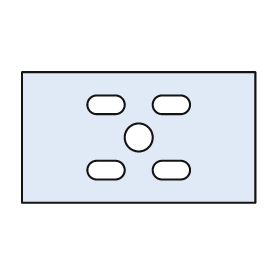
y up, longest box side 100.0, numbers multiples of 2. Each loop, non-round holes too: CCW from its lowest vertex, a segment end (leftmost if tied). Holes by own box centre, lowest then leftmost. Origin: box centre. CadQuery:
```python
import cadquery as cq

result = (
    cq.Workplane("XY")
    .moveTo(-50.0, -28.0)
    .lineTo(50.0, -28.0)
    .lineTo(50.0, 28.0)
    .lineTo(-50.0, 28.0)
    .close()
    .moveTo(-18.0, -18.0)
    .lineTo(-10.0, -18.0)
    .threePointArc((-6.0, -14.0), (-10.0, -10.0))
    .lineTo(-18.0, -10.0)
    .threePointArc((-22.0, -14.0), (-18.0, -18.0))
    .close()
    .moveTo(10.0, -18.0)
    .lineTo(18.0, -18.0)
    .threePointArc((22.0, -14.0), (18.0, -10.0))
    .lineTo(10.0, -10.0)
    .threePointArc((6.0, -14.0), (10.0, -18.0))
    .close()
    .moveTo(0.0, 0.0)
    .circle(6.0)
    .moveTo(-18.0, 10.0)
    .lineTo(-10.0, 10.0)
    .threePointArc((-6.0, 14.0), (-10.0, 18.0))
    .lineTo(-18.0, 18.0)
    .threePointArc((-22.0, 14.0), (-18.0, 10.0))
    .close()
    .moveTo(10.0, 10.0)
    .lineTo(18.0, 10.0)
    .threePointArc((22.0, 14.0), (18.0, 18.0))
    .lineTo(10.0, 18.0)
    .threePointArc((6.0, 14.0), (10.0, 10.0))
    .close()
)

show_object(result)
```